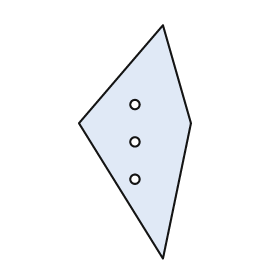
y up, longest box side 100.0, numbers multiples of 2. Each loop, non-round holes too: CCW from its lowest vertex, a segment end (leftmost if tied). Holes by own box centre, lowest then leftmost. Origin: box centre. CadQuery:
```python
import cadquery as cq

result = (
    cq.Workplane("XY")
    .moveTo(12.0, -50.0)
    .lineTo(24.0, 8.0)
    .lineTo(12.0, 50.0)
    .lineTo(-24.0, 8.0)
    .close()
    .moveTo(0.0, -16.0)
    .circle(2.0)
    .moveTo(0.0, 0.0)
    .circle(2.0)
    .moveTo(0.0, 16.0)
    .circle(2.0)
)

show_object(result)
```